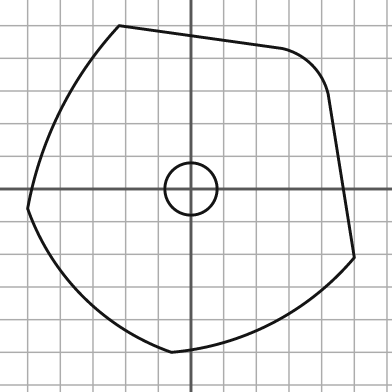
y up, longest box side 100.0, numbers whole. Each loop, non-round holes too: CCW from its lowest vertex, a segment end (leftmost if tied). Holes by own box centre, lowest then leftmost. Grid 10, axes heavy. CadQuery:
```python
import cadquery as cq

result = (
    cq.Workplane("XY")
    .moveTo(-6.0, -50.0)
    .threePointArc((25.0, -41.0), (50.0, -21.0))
    .lineTo(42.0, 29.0)
    .threePointArc((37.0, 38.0), (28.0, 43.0))
    .lineTo(-22.0, 50.0)
    .threePointArc((-40.0, 24.0), (-50.0, -6.0))
    .threePointArc((-33.0, -33.0), (-6.0, -50.0))
    .close()
    .moveTo(0.0, 0.0)
    .circle(8.0)
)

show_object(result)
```